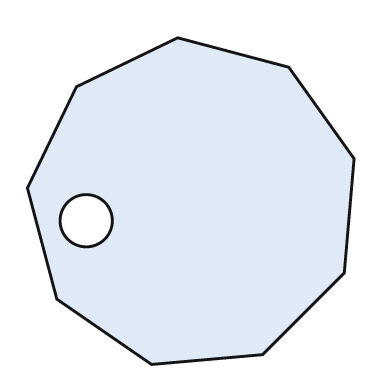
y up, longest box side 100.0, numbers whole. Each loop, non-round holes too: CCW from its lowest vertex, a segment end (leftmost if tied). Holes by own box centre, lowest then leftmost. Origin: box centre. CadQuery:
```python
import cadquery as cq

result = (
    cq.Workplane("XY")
    .moveTo(-12.0, -50.0)
    .lineTo(22.0, -47.0)
    .lineTo(47.0, -22.0)
    .lineTo(50.0, 13.0)
    .lineTo(30.0, 41.0)
    .lineTo(-4.0, 50.0)
    .lineTo(-35.0, 35.0)
    .lineTo(-50.0, 4.0)
    .lineTo(-41.0, -30.0)
    .close()
    .moveTo(-32.0, -6.0)
    .circle(8.0)
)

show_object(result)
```